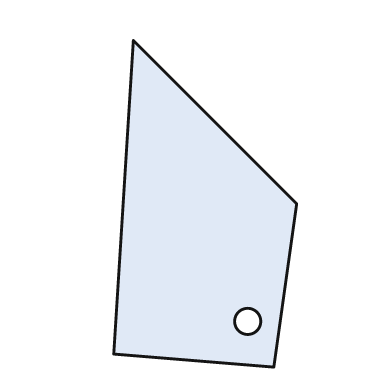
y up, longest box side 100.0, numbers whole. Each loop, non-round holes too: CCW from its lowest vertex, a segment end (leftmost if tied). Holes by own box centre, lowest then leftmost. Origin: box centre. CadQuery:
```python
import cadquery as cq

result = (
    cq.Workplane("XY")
    .moveTo(21.0, -50.0)
    .lineTo(28.0, 0.0)
    .lineTo(-22.0, 50.0)
    .lineTo(-28.0, -46.0)
    .close()
    .moveTo(13.0, -36.0)
    .circle(4.0)
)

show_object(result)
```